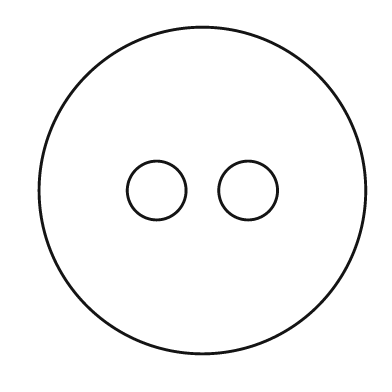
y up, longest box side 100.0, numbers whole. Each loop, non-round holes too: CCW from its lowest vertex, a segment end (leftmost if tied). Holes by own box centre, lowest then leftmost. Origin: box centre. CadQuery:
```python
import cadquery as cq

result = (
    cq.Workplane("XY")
    .moveTo(0.0, 0.0)
    .circle(50.0)
    .moveTo(-14.0, 0.0)
    .circle(9.0)
    .moveTo(14.0, 0.0)
    .circle(9.0)
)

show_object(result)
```